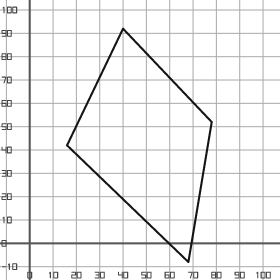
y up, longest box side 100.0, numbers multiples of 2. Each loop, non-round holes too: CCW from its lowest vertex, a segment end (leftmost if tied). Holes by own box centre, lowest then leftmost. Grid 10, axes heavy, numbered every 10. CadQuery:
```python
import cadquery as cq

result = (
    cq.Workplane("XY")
    .moveTo(68.0, -8.0)
    .lineTo(78.0, 52.0)
    .lineTo(40.0, 92.0)
    .lineTo(16.0, 42.0)
    .close()
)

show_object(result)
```